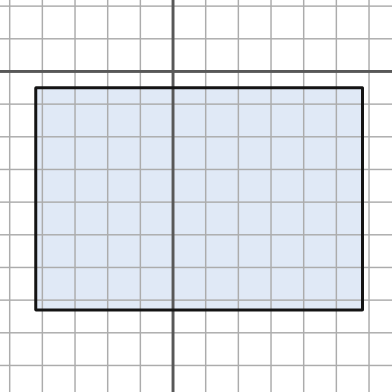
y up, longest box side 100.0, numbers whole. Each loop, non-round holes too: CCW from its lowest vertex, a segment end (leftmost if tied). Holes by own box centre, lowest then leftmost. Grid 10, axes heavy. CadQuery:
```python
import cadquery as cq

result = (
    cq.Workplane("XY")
    .moveTo(-42.0, -73.0)
    .lineTo(58.0, -73.0)
    .lineTo(58.0, -5.0)
    .lineTo(-42.0, -5.0)
    .close()
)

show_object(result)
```